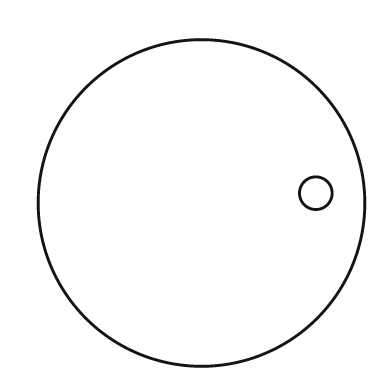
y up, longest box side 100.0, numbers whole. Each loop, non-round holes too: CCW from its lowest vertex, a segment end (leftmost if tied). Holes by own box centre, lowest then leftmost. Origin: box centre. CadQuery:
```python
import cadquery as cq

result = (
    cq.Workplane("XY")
    .moveTo(0.0, 0.0)
    .circle(50.0)
    .moveTo(35.0, 3.0)
    .circle(5.0)
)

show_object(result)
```